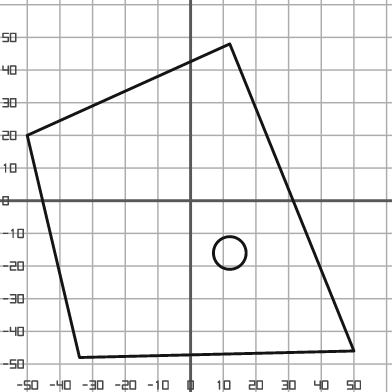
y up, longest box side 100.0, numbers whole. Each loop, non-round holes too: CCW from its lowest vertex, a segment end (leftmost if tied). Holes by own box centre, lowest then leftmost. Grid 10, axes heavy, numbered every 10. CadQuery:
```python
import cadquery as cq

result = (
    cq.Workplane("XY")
    .moveTo(-34.0, -48.0)
    .lineTo(50.0, -46.0)
    .lineTo(12.0, 48.0)
    .lineTo(-50.0, 20.0)
    .close()
    .moveTo(12.0, -16.0)
    .circle(5.0)
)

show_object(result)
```